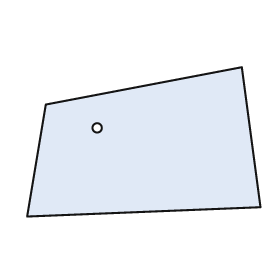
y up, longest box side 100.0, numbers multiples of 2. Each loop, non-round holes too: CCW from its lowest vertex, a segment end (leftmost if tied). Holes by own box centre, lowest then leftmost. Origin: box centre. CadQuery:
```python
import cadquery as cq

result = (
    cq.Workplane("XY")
    .moveTo(-50.0, -32.0)
    .lineTo(50.0, -28.0)
    .lineTo(42.0, 32.0)
    .lineTo(-42.0, 16.0)
    .close()
    .moveTo(-20.0, 6.0)
    .circle(2.0)
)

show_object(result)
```